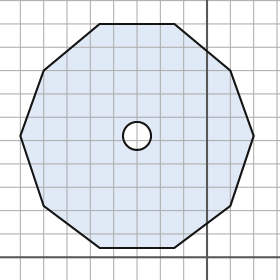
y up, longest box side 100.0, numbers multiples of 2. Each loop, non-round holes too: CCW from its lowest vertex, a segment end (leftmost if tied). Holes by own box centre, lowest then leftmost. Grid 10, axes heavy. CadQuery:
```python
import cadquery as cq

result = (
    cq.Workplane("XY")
    .moveTo(-46.0, 4.0)
    .lineTo(-14.0, 4.0)
    .lineTo(10.0, 22.0)
    .lineTo(20.0, 52.0)
    .lineTo(10.0, 80.0)
    .lineTo(-14.0, 100.0)
    .lineTo(-46.0, 100.0)
    .lineTo(-70.0, 80.0)
    .lineTo(-80.0, 52.0)
    .lineTo(-70.0, 22.0)
    .close()
    .moveTo(-30.0, 52.0)
    .circle(6.0)
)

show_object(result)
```